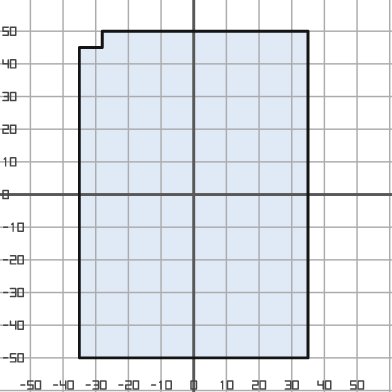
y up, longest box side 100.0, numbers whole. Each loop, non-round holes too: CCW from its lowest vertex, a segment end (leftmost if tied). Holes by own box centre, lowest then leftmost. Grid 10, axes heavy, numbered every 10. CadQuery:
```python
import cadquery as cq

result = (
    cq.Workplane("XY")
    .moveTo(-35.0, -50.0)
    .lineTo(35.0, -50.0)
    .lineTo(35.0, 50.0)
    .lineTo(-28.0, 50.0)
    .lineTo(-28.0, 45.0)
    .lineTo(-35.0, 45.0)
    .close()
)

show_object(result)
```